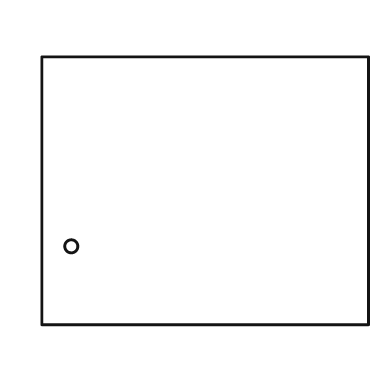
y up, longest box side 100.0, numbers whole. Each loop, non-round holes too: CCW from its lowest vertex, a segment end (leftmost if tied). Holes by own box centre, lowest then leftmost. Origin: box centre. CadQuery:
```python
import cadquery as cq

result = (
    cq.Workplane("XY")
    .moveTo(-50.0, -41.0)
    .lineTo(50.0, -41.0)
    .lineTo(50.0, 41.0)
    .lineTo(-50.0, 41.0)
    .close()
    .moveTo(-41.0, -17.0)
    .circle(2.0)
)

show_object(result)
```